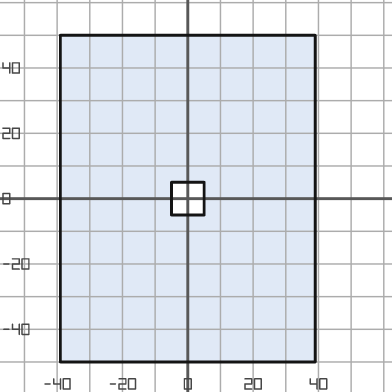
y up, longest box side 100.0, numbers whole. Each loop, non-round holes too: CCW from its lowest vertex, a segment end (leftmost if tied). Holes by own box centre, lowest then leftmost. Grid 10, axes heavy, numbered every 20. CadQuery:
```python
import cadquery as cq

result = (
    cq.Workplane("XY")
    .moveTo(-39.0, -50.0)
    .lineTo(39.0, -50.0)
    .lineTo(39.0, 50.0)
    .lineTo(-39.0, 50.0)
    .close()
    .moveTo(-5.0, -5.0)
    .lineTo(5.0, -5.0)
    .lineTo(5.0, 5.0)
    .lineTo(-5.0, 5.0)
    .close()
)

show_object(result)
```